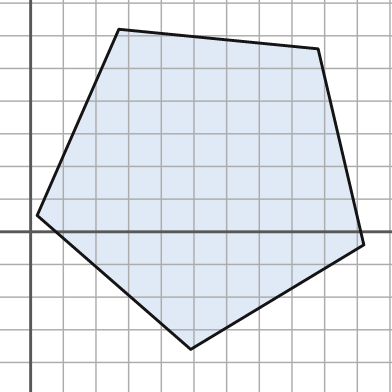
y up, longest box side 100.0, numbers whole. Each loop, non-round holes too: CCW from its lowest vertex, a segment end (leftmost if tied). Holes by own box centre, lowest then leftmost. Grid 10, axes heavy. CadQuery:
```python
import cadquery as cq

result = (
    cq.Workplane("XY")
    .moveTo(49.0, -36.0)
    .lineTo(102.0, -4.0)
    .lineTo(88.0, 56.0)
    .lineTo(27.0, 62.0)
    .lineTo(2.0, 5.0)
    .close()
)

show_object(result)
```